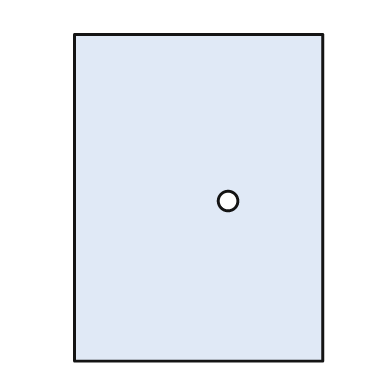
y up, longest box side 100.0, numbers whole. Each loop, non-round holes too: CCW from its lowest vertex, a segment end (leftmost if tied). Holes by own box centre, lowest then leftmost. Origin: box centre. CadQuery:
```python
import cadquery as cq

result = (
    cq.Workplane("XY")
    .moveTo(-38.0, -50.0)
    .lineTo(38.0, -50.0)
    .lineTo(38.0, 50.0)
    .lineTo(-38.0, 50.0)
    .close()
    .moveTo(9.0, -1.0)
    .circle(3.0)
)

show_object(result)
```